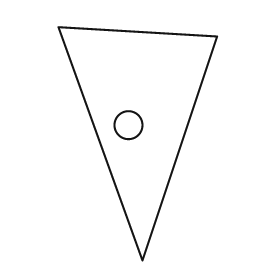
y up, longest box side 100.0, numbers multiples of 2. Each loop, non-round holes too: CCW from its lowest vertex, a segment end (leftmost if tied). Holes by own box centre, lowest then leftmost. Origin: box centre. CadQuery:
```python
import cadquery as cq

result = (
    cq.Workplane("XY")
    .moveTo(2.0, -50.0)
    .lineTo(34.0, 46.0)
    .lineTo(-34.0, 50.0)
    .close()
    .moveTo(-4.0, 8.0)
    .circle(6.0)
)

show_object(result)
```